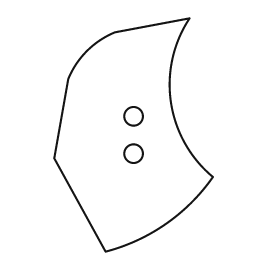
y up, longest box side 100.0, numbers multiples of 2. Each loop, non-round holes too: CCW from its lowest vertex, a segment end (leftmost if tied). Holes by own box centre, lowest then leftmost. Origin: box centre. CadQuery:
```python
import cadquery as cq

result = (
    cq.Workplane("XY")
    .moveTo(-12.0, -50.0)
    .threePointArc((14.0, -38.0), (34.0, -18.0))
    .threePointArc((16.0, 14.0), (24.0, 50.0))
    .lineTo(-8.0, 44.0)
    .threePointArc((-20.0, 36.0), (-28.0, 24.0))
    .lineTo(-34.0, -10.0)
    .close()
    .moveTo(0.0, -8.0)
    .circle(4.0)
    .moveTo(0.0, 8.0)
    .circle(4.0)
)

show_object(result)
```